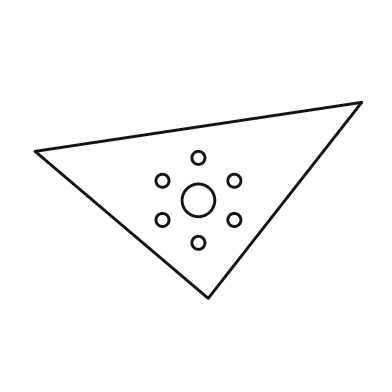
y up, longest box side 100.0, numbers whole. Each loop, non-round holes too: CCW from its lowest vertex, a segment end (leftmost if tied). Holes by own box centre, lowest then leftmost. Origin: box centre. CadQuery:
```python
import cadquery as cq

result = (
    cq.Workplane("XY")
    .moveTo(3.0, -30.0)
    .lineTo(50.0, 30.0)
    .lineTo(-50.0, 15.0)
    .close()
    .moveTo(0.0, -13.0)
    .circle(2.0)
    .moveTo(-11.0, -6.0)
    .circle(2.0)
    .moveTo(11.0, -6.0)
    .circle(2.0)
    .moveTo(0.0, 0.0)
    .circle(5.0)
    .moveTo(-11.0, 6.0)
    .circle(2.0)
    .moveTo(11.0, 6.0)
    .circle(2.0)
    .moveTo(0.0, 13.0)
    .circle(2.0)
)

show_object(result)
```